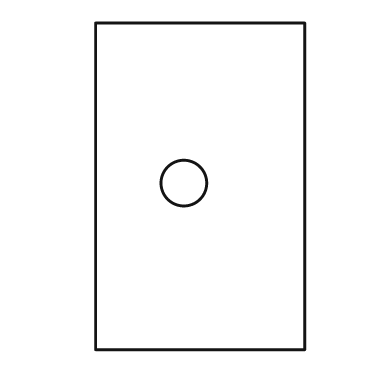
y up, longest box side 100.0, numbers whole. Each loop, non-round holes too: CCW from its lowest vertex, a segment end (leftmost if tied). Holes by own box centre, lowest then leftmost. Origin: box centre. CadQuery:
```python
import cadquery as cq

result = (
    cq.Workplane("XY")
    .moveTo(-32.0, -50.0)
    .lineTo(32.0, -50.0)
    .lineTo(32.0, 50.0)
    .lineTo(-32.0, 50.0)
    .close()
    .moveTo(-5.0, 1.0)
    .circle(7.0)
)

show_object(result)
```